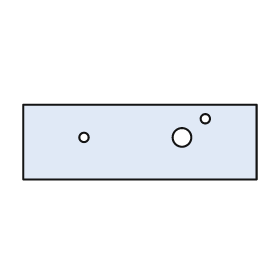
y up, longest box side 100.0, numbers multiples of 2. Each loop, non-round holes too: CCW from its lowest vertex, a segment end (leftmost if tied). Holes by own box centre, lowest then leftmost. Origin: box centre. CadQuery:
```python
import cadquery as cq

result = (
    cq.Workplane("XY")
    .moveTo(-50.0, -16.0)
    .lineTo(50.0, -16.0)
    .lineTo(50.0, 16.0)
    .lineTo(-50.0, 16.0)
    .close()
    .moveTo(-24.0, 2.0)
    .circle(2.0)
    .moveTo(18.0, 2.0)
    .circle(4.0)
    .moveTo(28.0, 10.0)
    .circle(2.0)
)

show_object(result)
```